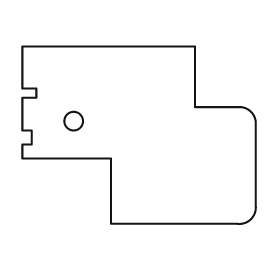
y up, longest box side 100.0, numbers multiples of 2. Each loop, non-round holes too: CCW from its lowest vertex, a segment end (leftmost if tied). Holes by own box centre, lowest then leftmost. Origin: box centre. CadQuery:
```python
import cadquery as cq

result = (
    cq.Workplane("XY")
    .moveTo(-12.0, -38.0)
    .lineTo(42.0, -38.0)
    .threePointArc((48.0, -36.0), (50.0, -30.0))
    .lineTo(50.0, 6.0)
    .threePointArc((48.0, 10.0), (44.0, 12.0))
    .lineTo(24.0, 12.0)
    .lineTo(24.0, 38.0)
    .lineTo(-50.0, 38.0)
    .lineTo(-50.0, 20.0)
    .lineTo(-44.0, 20.0)
    .lineTo(-44.0, 16.0)
    .lineTo(-50.0, 16.0)
    .lineTo(-50.0, 2.0)
    .lineTo(-46.0, 2.0)
    .lineTo(-46.0, -4.0)
    .lineTo(-50.0, -4.0)
    .lineTo(-50.0, -10.0)
    .lineTo(-12.0, -10.0)
    .close()
    .moveTo(-28.0, 6.0)
    .circle(4.0)
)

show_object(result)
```